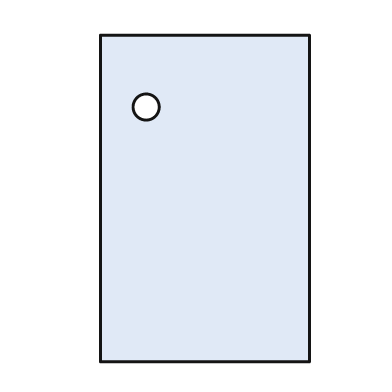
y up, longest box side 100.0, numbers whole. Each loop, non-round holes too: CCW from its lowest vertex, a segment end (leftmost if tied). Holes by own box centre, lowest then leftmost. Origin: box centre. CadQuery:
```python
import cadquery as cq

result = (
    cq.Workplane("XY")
    .moveTo(-32.0, -50.0)
    .lineTo(32.0, -50.0)
    .lineTo(32.0, 50.0)
    .lineTo(-32.0, 50.0)
    .close()
    .moveTo(-18.0, 28.0)
    .circle(4.0)
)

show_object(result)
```